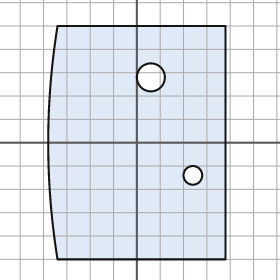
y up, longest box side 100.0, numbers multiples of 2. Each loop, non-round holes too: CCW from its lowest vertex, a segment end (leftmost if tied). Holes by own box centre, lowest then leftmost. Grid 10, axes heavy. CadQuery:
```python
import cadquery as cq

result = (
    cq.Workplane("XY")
    .moveTo(-34.0, -50.0)
    .lineTo(38.0, -50.0)
    .lineTo(38.0, 50.0)
    .lineTo(-34.0, 50.0)
    .threePointArc((-38.0, 0.0), (-34.0, -50.0))
    .close()
    .moveTo(24.0, -14.0)
    .circle(4.0)
    .moveTo(6.0, 28.0)
    .circle(6.0)
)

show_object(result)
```